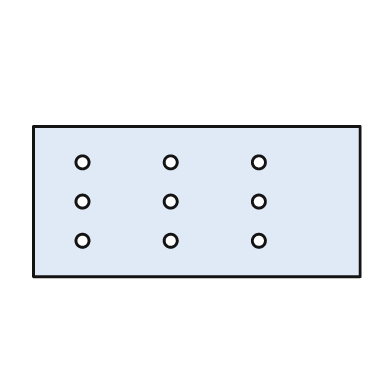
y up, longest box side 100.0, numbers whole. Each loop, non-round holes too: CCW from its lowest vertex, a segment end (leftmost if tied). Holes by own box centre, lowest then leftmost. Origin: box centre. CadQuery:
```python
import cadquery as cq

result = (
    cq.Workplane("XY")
    .moveTo(-50.0, -23.0)
    .lineTo(50.0, -23.0)
    .lineTo(50.0, 23.0)
    .lineTo(-50.0, 23.0)
    .close()
    .moveTo(-35.0, -12.0)
    .circle(2.0)
    .moveTo(-8.0, -12.0)
    .circle(2.0)
    .moveTo(19.0, -12.0)
    .circle(2.0)
    .moveTo(-35.0, 0.0)
    .circle(2.0)
    .moveTo(-8.0, 0.0)
    .circle(2.0)
    .moveTo(19.0, 0.0)
    .circle(2.0)
    .moveTo(-35.0, 12.0)
    .circle(2.0)
    .moveTo(-8.0, 12.0)
    .circle(2.0)
    .moveTo(19.0, 12.0)
    .circle(2.0)
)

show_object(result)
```